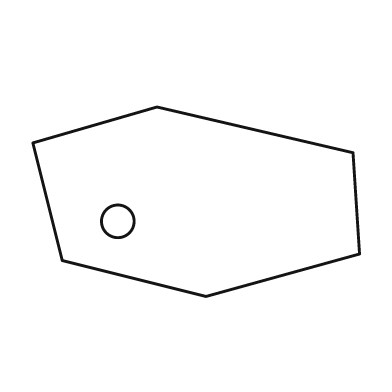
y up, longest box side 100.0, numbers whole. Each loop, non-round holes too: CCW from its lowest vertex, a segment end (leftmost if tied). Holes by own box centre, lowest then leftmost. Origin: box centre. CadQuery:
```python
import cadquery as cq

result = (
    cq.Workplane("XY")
    .moveTo(3.0, -29.0)
    .lineTo(50.0, -16.0)
    .lineTo(48.0, 15.0)
    .lineTo(-12.0, 29.0)
    .lineTo(-50.0, 18.0)
    .lineTo(-41.0, -18.0)
    .close()
    .moveTo(-24.0, -6.0)
    .circle(5.0)
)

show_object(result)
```